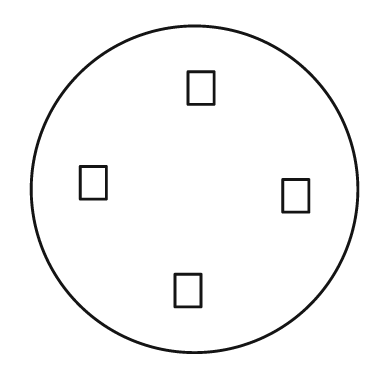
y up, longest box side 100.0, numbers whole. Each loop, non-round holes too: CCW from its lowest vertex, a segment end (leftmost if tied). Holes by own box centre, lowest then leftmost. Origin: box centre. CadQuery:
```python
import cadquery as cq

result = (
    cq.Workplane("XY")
    .moveTo(0.0, 0.0)
    .circle(50.0)
    .moveTo(-6.0, -36.0)
    .lineTo(2.0, -36.0)
    .lineTo(2.0, -26.0)
    .lineTo(-6.0, -26.0)
    .close()
    .moveTo(27.0, -7.0)
    .lineTo(35.0, -7.0)
    .lineTo(35.0, 3.0)
    .lineTo(27.0, 3.0)
    .close()
    .moveTo(-35.0, -3.0)
    .lineTo(-27.0, -3.0)
    .lineTo(-27.0, 7.0)
    .lineTo(-35.0, 7.0)
    .close()
    .moveTo(-2.0, 26.0)
    .lineTo(6.0, 26.0)
    .lineTo(6.0, 36.0)
    .lineTo(-2.0, 36.0)
    .close()
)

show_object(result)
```